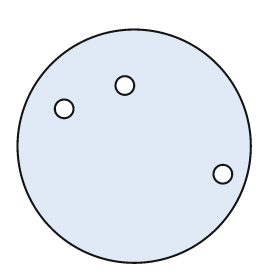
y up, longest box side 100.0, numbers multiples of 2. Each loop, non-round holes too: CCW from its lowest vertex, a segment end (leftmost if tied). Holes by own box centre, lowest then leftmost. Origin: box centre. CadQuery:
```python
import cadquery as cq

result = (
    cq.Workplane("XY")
    .moveTo(0.0, 0.0)
    .circle(50.0)
    .moveTo(38.0, -12.0)
    .circle(4.0)
    .moveTo(-30.0, 16.0)
    .circle(4.0)
    .moveTo(-4.0, 26.0)
    .circle(4.0)
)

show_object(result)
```